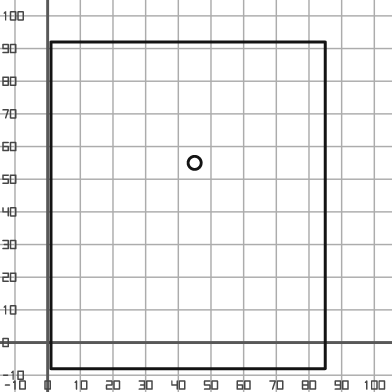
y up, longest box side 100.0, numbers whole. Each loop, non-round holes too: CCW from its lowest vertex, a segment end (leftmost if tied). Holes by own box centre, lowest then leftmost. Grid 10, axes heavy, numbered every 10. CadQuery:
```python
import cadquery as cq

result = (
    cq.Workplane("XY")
    .moveTo(1.0, -8.0)
    .lineTo(85.0, -8.0)
    .lineTo(85.0, 92.0)
    .lineTo(1.0, 92.0)
    .close()
    .moveTo(45.0, 55.0)
    .circle(2.0)
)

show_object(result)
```